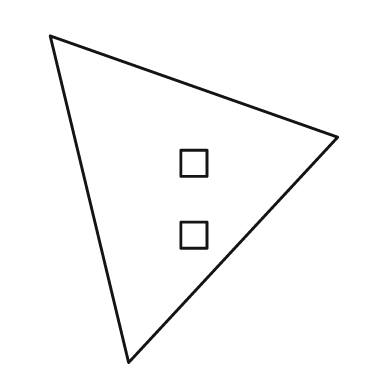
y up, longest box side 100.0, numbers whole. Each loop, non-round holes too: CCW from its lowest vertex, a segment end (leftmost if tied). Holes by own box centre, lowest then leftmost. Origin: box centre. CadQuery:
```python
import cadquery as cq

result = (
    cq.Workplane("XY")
    .moveTo(-20.0, -50.0)
    .lineTo(44.0, 19.0)
    .lineTo(-44.0, 50.0)
    .close()
    .moveTo(-4.0, -15.0)
    .lineTo(4.0, -15.0)
    .lineTo(4.0, -7.0)
    .lineTo(-4.0, -7.0)
    .close()
    .moveTo(-4.0, 7.0)
    .lineTo(4.0, 7.0)
    .lineTo(4.0, 15.0)
    .lineTo(-4.0, 15.0)
    .close()
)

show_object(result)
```